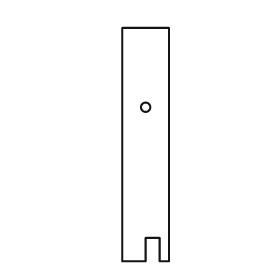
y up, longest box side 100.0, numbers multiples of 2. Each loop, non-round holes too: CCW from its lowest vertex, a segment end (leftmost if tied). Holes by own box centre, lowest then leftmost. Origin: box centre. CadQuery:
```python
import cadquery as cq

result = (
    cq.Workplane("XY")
    .moveTo(-10.0, -50.0)
    .lineTo(0.0, -50.0)
    .lineTo(0.0, -40.0)
    .lineTo(6.0, -40.0)
    .lineTo(6.0, -50.0)
    .lineTo(10.0, -50.0)
    .lineTo(10.0, 50.0)
    .lineTo(-10.0, 50.0)
    .close()
    .moveTo(0.0, 16.0)
    .circle(2.0)
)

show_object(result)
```